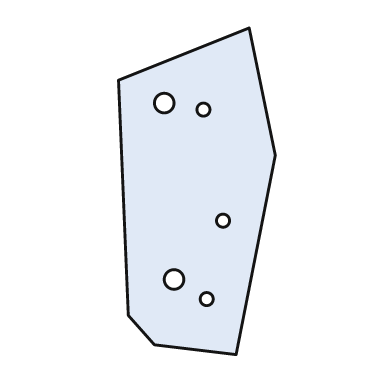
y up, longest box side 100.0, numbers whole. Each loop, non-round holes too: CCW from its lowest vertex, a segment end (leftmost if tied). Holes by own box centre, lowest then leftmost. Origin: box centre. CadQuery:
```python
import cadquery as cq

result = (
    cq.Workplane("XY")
    .moveTo(12.0, -50.0)
    .lineTo(24.0, 11.0)
    .lineTo(16.0, 50.0)
    .lineTo(-24.0, 34.0)
    .lineTo(-21.0, -38.0)
    .lineTo(-13.0, -47.0)
    .close()
    .moveTo(3.0, -33.0)
    .circle(2.0)
    .moveTo(-7.0, -27.0)
    .circle(3.0)
    .moveTo(8.0, -9.0)
    .circle(2.0)
    .moveTo(2.0, 25.0)
    .circle(2.0)
    .moveTo(-10.0, 27.0)
    .circle(3.0)
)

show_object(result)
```